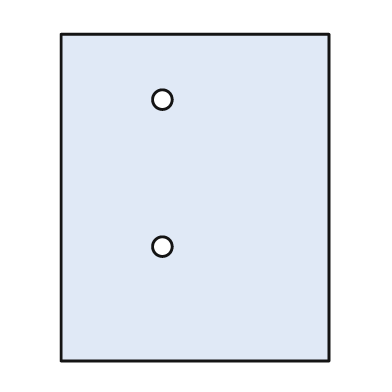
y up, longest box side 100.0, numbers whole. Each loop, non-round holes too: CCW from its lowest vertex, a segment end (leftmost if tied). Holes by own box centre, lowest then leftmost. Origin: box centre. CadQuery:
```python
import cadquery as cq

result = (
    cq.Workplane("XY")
    .moveTo(-41.0, -50.0)
    .lineTo(41.0, -50.0)
    .lineTo(41.0, 50.0)
    .lineTo(-41.0, 50.0)
    .close()
    .moveTo(-10.0, -15.0)
    .circle(3.0)
    .moveTo(-10.0, 30.0)
    .circle(3.0)
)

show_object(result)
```